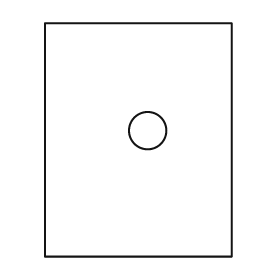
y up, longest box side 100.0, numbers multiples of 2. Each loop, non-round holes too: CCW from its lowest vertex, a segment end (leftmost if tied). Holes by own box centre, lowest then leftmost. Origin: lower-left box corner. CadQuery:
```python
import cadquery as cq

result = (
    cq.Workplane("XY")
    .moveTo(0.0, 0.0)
    .lineTo(80.0, 0.0)
    .lineTo(80.0, 100.0)
    .lineTo(0.0, 100.0)
    .close()
    .moveTo(44.0, 54.0)
    .circle(8.0)
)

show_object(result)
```